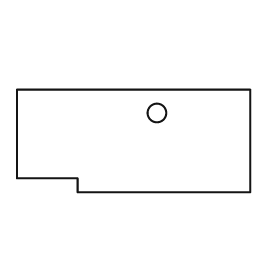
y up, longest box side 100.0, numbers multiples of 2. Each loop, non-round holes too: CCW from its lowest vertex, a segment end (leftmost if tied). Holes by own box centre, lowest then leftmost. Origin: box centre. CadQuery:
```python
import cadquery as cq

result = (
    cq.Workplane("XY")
    .moveTo(-24.0, -22.0)
    .lineTo(50.0, -22.0)
    .lineTo(50.0, 22.0)
    .lineTo(-50.0, 22.0)
    .lineTo(-50.0, -16.0)
    .lineTo(-24.0, -16.0)
    .close()
    .moveTo(10.0, 12.0)
    .circle(4.0)
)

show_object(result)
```